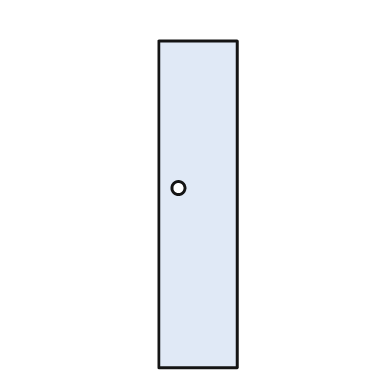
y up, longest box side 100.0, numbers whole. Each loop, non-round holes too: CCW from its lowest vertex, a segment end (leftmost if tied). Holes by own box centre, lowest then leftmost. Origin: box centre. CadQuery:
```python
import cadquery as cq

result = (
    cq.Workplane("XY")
    .moveTo(-12.0, -50.0)
    .lineTo(12.0, -50.0)
    .lineTo(12.0, 50.0)
    .lineTo(-12.0, 50.0)
    .close()
    .moveTo(-6.0, 5.0)
    .circle(2.0)
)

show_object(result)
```